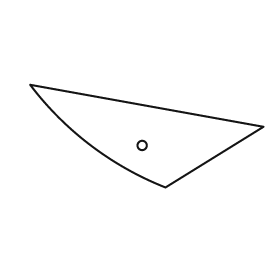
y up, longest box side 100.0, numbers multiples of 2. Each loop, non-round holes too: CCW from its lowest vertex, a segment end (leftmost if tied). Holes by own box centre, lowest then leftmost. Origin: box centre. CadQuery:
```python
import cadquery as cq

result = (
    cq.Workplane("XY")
    .moveTo(8.0, -22.0)
    .lineTo(50.0, 4.0)
    .lineTo(-50.0, 22.0)
    .threePointArc((-24.0, -4.0), (8.0, -22.0))
    .close()
    .moveTo(-2.0, -4.0)
    .circle(2.0)
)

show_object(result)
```